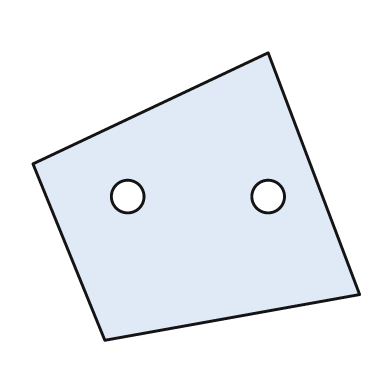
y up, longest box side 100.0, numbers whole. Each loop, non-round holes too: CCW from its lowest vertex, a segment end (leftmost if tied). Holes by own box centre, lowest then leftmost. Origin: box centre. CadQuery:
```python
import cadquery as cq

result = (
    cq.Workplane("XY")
    .moveTo(-28.0, -44.0)
    .lineTo(50.0, -30.0)
    .lineTo(22.0, 44.0)
    .lineTo(-50.0, 10.0)
    .close()
    .moveTo(-21.0, 0.0)
    .circle(5.0)
    .moveTo(22.0, 0.0)
    .circle(5.0)
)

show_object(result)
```